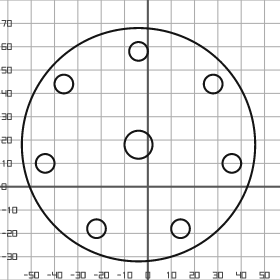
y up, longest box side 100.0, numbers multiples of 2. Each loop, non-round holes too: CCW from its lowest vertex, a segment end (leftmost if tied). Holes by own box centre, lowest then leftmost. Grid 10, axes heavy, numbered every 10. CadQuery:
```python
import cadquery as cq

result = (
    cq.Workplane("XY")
    .moveTo(-4.0, 18.0)
    .circle(50.0)
    .moveTo(-22.0, -18.0)
    .circle(4.0)
    .moveTo(14.0, -18.0)
    .circle(4.0)
    .moveTo(-44.0, 10.0)
    .circle(4.0)
    .moveTo(36.0, 10.0)
    .circle(4.0)
    .moveTo(-4.0, 18.0)
    .circle(6.0)
    .moveTo(-36.0, 44.0)
    .circle(4.0)
    .moveTo(28.0, 44.0)
    .circle(4.0)
    .moveTo(-4.0, 58.0)
    .circle(4.0)
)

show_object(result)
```